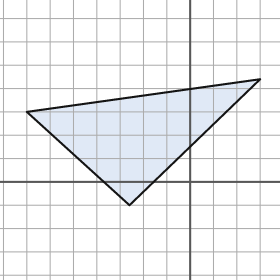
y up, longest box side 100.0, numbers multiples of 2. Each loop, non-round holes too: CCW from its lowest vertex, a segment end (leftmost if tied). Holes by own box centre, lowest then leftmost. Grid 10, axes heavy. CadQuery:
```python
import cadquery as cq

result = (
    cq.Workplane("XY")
    .moveTo(-26.0, -10.0)
    .lineTo(30.0, 44.0)
    .lineTo(-70.0, 30.0)
    .close()
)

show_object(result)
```